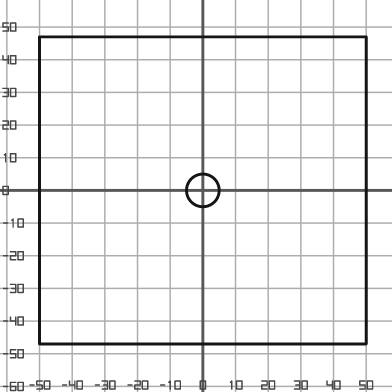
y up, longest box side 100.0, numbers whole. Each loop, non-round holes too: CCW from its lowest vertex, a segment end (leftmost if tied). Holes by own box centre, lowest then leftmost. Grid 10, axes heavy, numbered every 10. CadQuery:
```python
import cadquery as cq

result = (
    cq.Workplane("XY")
    .moveTo(-50.0, -47.0)
    .lineTo(50.0, -47.0)
    .lineTo(50.0, 47.0)
    .lineTo(-50.0, 47.0)
    .close()
    .moveTo(0.0, 0.0)
    .circle(5.0)
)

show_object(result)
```